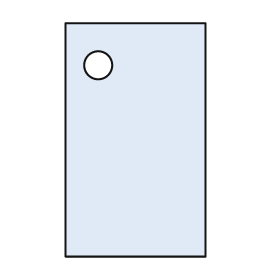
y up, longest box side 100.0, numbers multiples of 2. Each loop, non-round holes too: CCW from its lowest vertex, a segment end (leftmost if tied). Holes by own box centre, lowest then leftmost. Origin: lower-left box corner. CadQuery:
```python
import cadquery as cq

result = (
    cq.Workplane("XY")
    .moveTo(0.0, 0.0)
    .lineTo(60.0, 0.0)
    .lineTo(60.0, 100.0)
    .lineTo(0.0, 100.0)
    .close()
    .moveTo(14.0, 82.0)
    .circle(6.0)
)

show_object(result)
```